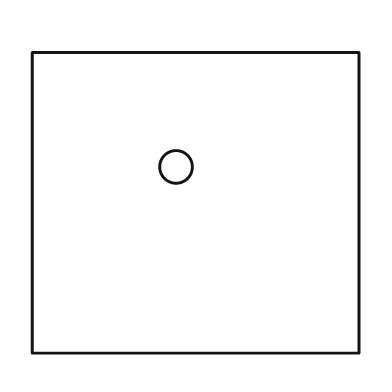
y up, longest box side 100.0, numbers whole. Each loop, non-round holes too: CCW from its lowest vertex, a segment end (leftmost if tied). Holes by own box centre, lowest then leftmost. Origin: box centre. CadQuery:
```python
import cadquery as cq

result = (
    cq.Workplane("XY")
    .moveTo(-50.0, -46.0)
    .lineTo(50.0, -46.0)
    .lineTo(50.0, 46.0)
    .lineTo(-50.0, 46.0)
    .close()
    .moveTo(-6.0, 11.0)
    .circle(5.0)
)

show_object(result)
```